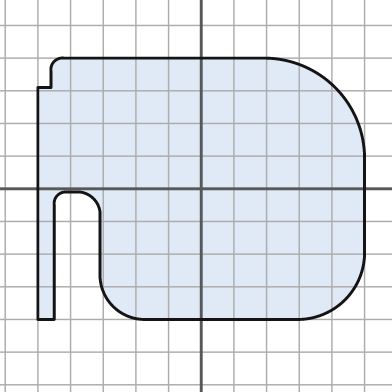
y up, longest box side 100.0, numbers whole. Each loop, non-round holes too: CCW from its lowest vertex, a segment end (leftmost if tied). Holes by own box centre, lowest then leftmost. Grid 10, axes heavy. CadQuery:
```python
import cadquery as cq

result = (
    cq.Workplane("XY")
    .moveTo(-50.0, -40.0)
    .lineTo(-45.0, -40.0)
    .lineTo(-45.0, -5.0)
    .threePointArc((-44.0, -2.0), (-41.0, -1.0))
    .lineTo(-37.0, -1.0)
    .threePointArc((-33.0, -3.0), (-31.0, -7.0))
    .lineTo(-31.0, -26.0)
    .threePointArc((-27.0, -36.0), (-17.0, -40.0))
    .lineTo(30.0, -40.0)
    .threePointArc((44.0, -34.0), (50.0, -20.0))
    .lineTo(50.0, 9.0)
    .threePointArc((41.0, 31.0), (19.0, 40.0))
    .lineTo(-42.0, 40.0)
    .threePointArc((-45.0, 39.0), (-46.0, 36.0))
    .lineTo(-46.0, 31.0)
    .lineTo(-50.0, 31.0)
    .close()
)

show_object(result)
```